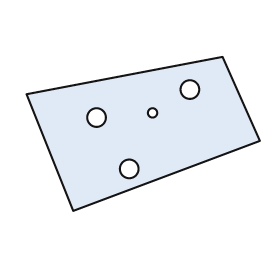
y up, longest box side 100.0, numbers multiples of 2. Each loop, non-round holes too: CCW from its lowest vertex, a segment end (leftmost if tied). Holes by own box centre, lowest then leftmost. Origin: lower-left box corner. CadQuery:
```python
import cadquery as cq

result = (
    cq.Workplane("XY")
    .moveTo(20.0, 0.0)
    .lineTo(100.0, 30.0)
    .lineTo(84.0, 66.0)
    .lineTo(0.0, 50.0)
    .close()
    .moveTo(44.0, 18.0)
    .circle(4.0)
    .moveTo(30.0, 40.0)
    .circle(4.0)
    .moveTo(54.0, 42.0)
    .circle(2.0)
    .moveTo(70.0, 52.0)
    .circle(4.0)
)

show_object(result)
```